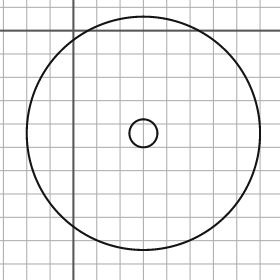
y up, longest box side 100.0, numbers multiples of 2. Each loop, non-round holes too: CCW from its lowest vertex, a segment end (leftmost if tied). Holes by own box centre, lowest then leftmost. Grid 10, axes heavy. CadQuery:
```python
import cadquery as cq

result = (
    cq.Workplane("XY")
    .moveTo(30.0, -44.0)
    .circle(50.0)
    .moveTo(30.0, -44.0)
    .circle(6.0)
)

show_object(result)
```